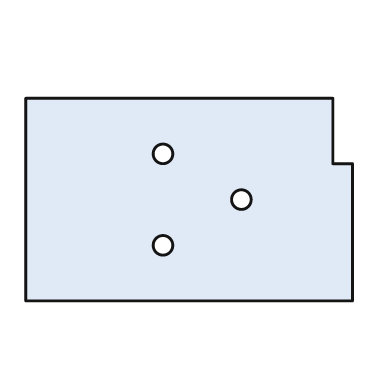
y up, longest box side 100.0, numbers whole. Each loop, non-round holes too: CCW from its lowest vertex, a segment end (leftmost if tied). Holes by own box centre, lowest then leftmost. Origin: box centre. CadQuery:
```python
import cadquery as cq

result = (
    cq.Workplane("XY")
    .moveTo(-50.0, -31.0)
    .lineTo(50.0, -31.0)
    .lineTo(50.0, 11.0)
    .lineTo(44.0, 11.0)
    .lineTo(44.0, 31.0)
    .lineTo(-50.0, 31.0)
    .close()
    .moveTo(-8.0, -14.0)
    .circle(3.0)
    .moveTo(16.0, 0.0)
    .circle(3.0)
    .moveTo(-8.0, 14.0)
    .circle(3.0)
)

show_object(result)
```